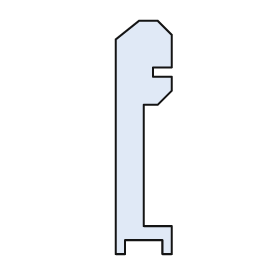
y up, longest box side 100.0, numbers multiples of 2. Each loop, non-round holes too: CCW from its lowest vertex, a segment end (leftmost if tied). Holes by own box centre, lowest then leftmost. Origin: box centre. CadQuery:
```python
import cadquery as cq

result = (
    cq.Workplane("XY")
    .moveTo(-12.0, -50.0)
    .lineTo(-8.0, -50.0)
    .lineTo(-8.0, -44.0)
    .lineTo(8.0, -44.0)
    .lineTo(8.0, -50.0)
    .lineTo(12.0, -50.0)
    .lineTo(12.0, -38.0)
    .lineTo(0.0, -38.0)
    .lineTo(0.0, 14.0)
    .lineTo(6.0, 14.0)
    .lineTo(12.0, 20.0)
    .lineTo(12.0, 26.0)
    .lineTo(4.0, 26.0)
    .lineTo(4.0, 30.0)
    .lineTo(12.0, 30.0)
    .lineTo(12.0, 44.0)
    .lineTo(6.0, 50.0)
    .lineTo(-2.0, 50.0)
    .lineTo(-12.0, 42.0)
    .close()
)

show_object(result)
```